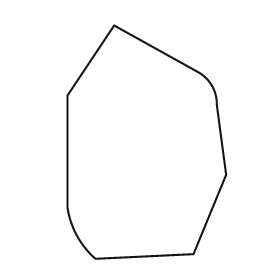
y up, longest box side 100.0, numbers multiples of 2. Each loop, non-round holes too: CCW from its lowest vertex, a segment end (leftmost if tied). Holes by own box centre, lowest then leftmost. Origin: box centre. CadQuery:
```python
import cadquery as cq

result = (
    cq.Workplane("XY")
    .moveTo(-22.0, -50.0)
    .lineTo(20.0, -48.0)
    .lineTo(34.0, -14.0)
    .lineTo(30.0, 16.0)
    .threePointArc((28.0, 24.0), (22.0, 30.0))
    .lineTo(-14.0, 50.0)
    .lineTo(-34.0, 20.0)
    .lineTo(-34.0, -28.0)
    .threePointArc((-30.0, -40.0), (-22.0, -50.0))
    .close()
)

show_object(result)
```